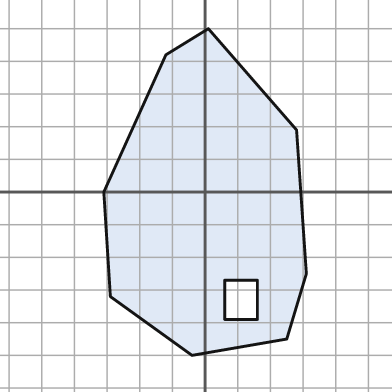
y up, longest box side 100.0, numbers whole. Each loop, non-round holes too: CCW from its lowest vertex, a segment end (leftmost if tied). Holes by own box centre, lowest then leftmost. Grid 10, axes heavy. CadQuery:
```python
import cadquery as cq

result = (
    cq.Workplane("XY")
    .moveTo(-4.0, -50.0)
    .lineTo(25.0, -45.0)
    .lineTo(31.0, -25.0)
    .lineTo(28.0, 19.0)
    .lineTo(1.0, 50.0)
    .lineTo(-12.0, 42.0)
    .lineTo(-31.0, 0.0)
    .lineTo(-29.0, -32.0)
    .close()
    .moveTo(6.0, -39.0)
    .lineTo(16.0, -39.0)
    .lineTo(16.0, -27.0)
    .lineTo(6.0, -27.0)
    .close()
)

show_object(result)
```